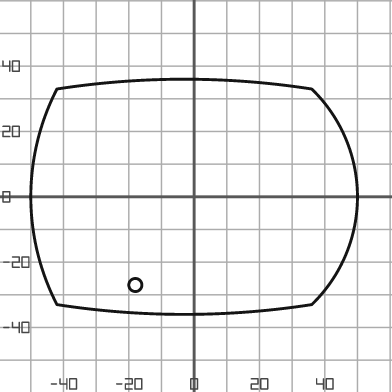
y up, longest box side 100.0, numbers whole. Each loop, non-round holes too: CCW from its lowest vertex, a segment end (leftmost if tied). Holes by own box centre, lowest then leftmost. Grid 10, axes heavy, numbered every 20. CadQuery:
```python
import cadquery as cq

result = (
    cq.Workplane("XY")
    .moveTo(-42.0, -33.0)
    .threePointArc((-3.0, -36.0), (36.0, -33.0))
    .threePointArc((50.0, 0.0), (36.0, 33.0))
    .threePointArc((-3.0, 36.0), (-42.0, 33.0))
    .threePointArc((-50.0, 0.0), (-42.0, -33.0))
    .close()
    .moveTo(-18.0, -27.0)
    .circle(2.0)
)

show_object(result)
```